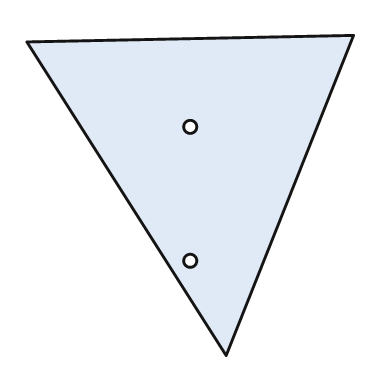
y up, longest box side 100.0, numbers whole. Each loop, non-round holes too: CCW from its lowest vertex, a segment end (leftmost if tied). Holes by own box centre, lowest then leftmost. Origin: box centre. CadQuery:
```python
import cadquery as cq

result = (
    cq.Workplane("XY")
    .moveTo(11.0, -49.0)
    .lineTo(50.0, 49.0)
    .lineTo(-50.0, 47.0)
    .close()
    .moveTo(0.0, -20.0)
    .circle(2.0)
    .moveTo(0.0, 21.0)
    .circle(2.0)
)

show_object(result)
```